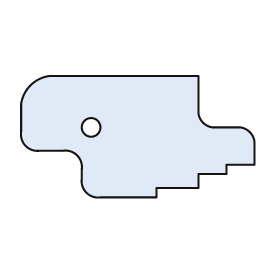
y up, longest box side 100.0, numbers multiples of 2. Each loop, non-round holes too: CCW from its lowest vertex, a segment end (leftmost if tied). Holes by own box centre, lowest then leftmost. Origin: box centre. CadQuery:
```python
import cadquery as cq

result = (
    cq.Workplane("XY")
    .moveTo(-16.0, -26.0)
    .lineTo(8.0, -26.0)
    .lineTo(8.0, -22.0)
    .lineTo(26.0, -22.0)
    .lineTo(26.0, -16.0)
    .lineTo(38.0, -16.0)
    .lineTo(38.0, -12.0)
    .lineTo(50.0, -12.0)
    .lineTo(50.0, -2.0)
    .threePointArc((48.0, 2.0), (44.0, 4.0))
    .lineTo(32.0, 4.0)
    .threePointArc((28.0, 6.0), (26.0, 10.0))
    .lineTo(26.0, 26.0)
    .lineTo(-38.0, 26.0)
    .threePointArc((-46.0, 22.0), (-50.0, 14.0))
    .lineTo(-50.0, 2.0)
    .threePointArc((-48.0, -4.0), (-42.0, -6.0))
    .lineTo(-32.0, -6.0)
    .threePointArc((-26.0, -8.0), (-24.0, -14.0))
    .lineTo(-24.0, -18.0)
    .threePointArc((-22.0, -24.0), (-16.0, -26.0))
    .close()
    .moveTo(-20.0, 4.0)
    .circle(4.0)
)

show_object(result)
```